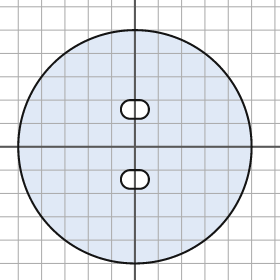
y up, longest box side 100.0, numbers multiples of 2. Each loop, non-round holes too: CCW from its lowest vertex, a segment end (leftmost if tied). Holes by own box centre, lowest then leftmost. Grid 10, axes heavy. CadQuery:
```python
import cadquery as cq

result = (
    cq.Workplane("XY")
    .moveTo(0.0, 0.0)
    .circle(50.0)
    .moveTo(-2.0, -18.0)
    .lineTo(2.0, -18.0)
    .threePointArc((6.0, -14.0), (2.0, -10.0))
    .lineTo(-2.0, -10.0)
    .threePointArc((-6.0, -14.0), (-2.0, -18.0))
    .close()
    .moveTo(-2.0, 12.0)
    .lineTo(2.0, 12.0)
    .threePointArc((6.0, 16.0), (2.0, 20.0))
    .lineTo(-2.0, 20.0)
    .threePointArc((-6.0, 16.0), (-2.0, 12.0))
    .close()
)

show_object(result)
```